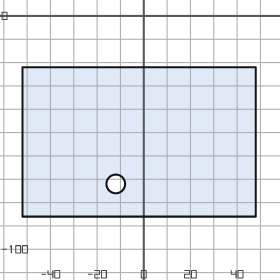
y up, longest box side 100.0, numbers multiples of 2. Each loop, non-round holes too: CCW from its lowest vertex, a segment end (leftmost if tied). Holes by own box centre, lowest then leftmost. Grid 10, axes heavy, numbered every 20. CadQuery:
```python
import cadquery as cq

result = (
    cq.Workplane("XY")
    .moveTo(-52.0, -86.0)
    .lineTo(48.0, -86.0)
    .lineTo(48.0, -22.0)
    .lineTo(-52.0, -22.0)
    .close()
    .moveTo(-12.0, -72.0)
    .circle(4.0)
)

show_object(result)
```